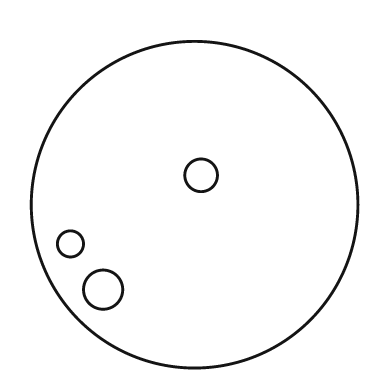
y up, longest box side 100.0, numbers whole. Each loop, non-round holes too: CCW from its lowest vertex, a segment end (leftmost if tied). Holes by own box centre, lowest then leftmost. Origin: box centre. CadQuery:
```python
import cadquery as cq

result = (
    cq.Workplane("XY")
    .moveTo(0.0, 0.0)
    .circle(50.0)
    .moveTo(-28.0, -26.0)
    .circle(6.0)
    .moveTo(-38.0, -12.0)
    .circle(4.0)
    .moveTo(2.0, 9.0)
    .circle(5.0)
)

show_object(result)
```